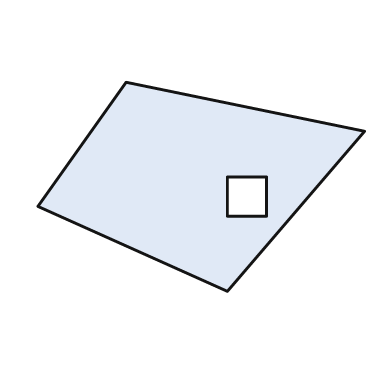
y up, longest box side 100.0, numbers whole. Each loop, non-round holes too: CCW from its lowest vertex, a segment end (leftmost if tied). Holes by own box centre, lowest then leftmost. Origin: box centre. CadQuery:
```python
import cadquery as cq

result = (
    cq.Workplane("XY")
    .moveTo(8.0, -32.0)
    .lineTo(50.0, 17.0)
    .lineTo(-23.0, 32.0)
    .lineTo(-50.0, -6.0)
    .close()
    .moveTo(8.0, -9.0)
    .lineTo(20.0, -9.0)
    .lineTo(20.0, 3.0)
    .lineTo(8.0, 3.0)
    .close()
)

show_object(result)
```